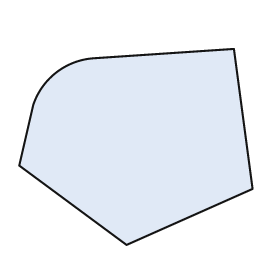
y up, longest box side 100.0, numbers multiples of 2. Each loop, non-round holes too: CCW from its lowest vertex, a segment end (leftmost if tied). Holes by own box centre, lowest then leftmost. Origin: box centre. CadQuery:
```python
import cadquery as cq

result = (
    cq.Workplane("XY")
    .moveTo(-4.0, -42.0)
    .lineTo(50.0, -18.0)
    .lineTo(42.0, 42.0)
    .lineTo(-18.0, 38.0)
    .threePointArc((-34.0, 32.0), (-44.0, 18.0))
    .lineTo(-50.0, -8.0)
    .close()
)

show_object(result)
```